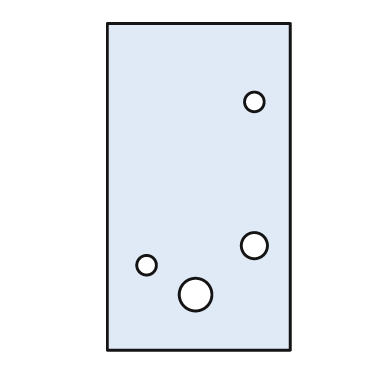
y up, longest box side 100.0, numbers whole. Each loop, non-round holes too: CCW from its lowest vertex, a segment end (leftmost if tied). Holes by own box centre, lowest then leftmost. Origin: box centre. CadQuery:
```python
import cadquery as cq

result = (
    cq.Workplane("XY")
    .moveTo(-28.0, -50.0)
    .lineTo(28.0, -50.0)
    .lineTo(28.0, 50.0)
    .lineTo(-28.0, 50.0)
    .close()
    .moveTo(-1.0, -33.0)
    .circle(5.0)
    .moveTo(-16.0, -24.0)
    .circle(3.0)
    .moveTo(17.0, -18.0)
    .circle(4.0)
    .moveTo(17.0, 26.0)
    .circle(3.0)
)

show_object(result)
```